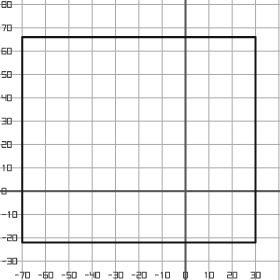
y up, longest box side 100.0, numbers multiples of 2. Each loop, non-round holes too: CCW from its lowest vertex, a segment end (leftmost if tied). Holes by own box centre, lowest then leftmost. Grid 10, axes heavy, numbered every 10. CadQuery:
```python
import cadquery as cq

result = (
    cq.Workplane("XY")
    .moveTo(-70.0, -22.0)
    .lineTo(30.0, -22.0)
    .lineTo(30.0, 66.0)
    .lineTo(-70.0, 66.0)
    .close()
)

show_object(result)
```